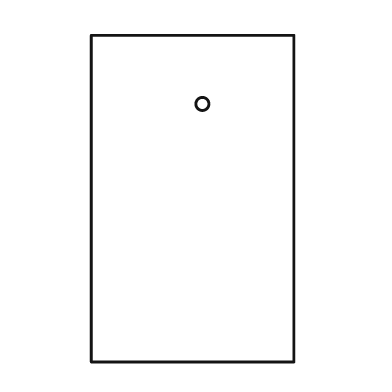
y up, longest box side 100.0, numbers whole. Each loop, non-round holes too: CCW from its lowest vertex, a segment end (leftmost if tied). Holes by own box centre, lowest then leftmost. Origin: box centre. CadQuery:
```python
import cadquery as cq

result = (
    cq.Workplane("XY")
    .moveTo(-31.0, -50.0)
    .lineTo(31.0, -50.0)
    .lineTo(31.0, 50.0)
    .lineTo(-31.0, 50.0)
    .close()
    .moveTo(3.0, 29.0)
    .circle(2.0)
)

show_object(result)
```